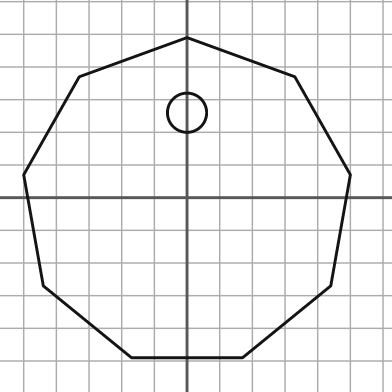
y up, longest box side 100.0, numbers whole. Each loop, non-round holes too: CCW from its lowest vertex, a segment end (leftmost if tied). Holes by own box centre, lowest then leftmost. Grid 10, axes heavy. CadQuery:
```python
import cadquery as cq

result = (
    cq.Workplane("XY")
    .moveTo(-17.0, -49.0)
    .lineTo(17.0, -49.0)
    .lineTo(44.0, -27.0)
    .lineTo(50.0, 7.0)
    .lineTo(33.0, 37.0)
    .lineTo(0.0, 49.0)
    .lineTo(-33.0, 37.0)
    .lineTo(-50.0, 7.0)
    .lineTo(-44.0, -27.0)
    .close()
    .moveTo(0.0, 26.0)
    .circle(6.0)
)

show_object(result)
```